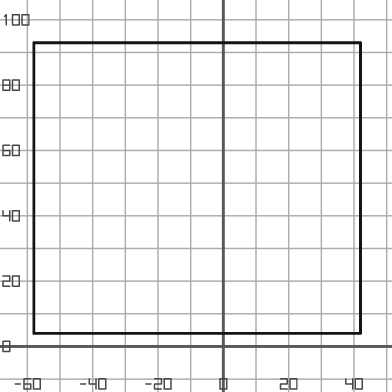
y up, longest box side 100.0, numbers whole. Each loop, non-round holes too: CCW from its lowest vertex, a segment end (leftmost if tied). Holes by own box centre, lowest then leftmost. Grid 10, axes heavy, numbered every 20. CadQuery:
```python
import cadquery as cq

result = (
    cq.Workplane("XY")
    .moveTo(-58.0, 4.0)
    .lineTo(42.0, 4.0)
    .lineTo(42.0, 93.0)
    .lineTo(-58.0, 93.0)
    .close()
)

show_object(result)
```